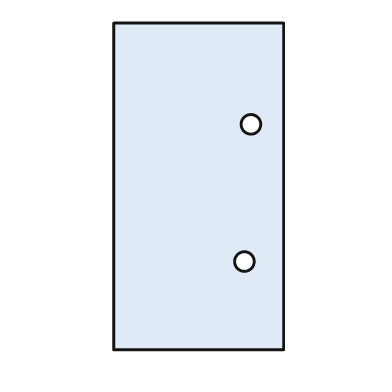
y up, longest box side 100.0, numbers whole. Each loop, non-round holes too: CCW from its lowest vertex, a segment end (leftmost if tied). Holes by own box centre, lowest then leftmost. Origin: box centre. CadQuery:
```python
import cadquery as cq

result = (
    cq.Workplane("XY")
    .moveTo(-26.0, -50.0)
    .lineTo(26.0, -50.0)
    .lineTo(26.0, 50.0)
    .lineTo(-26.0, 50.0)
    .close()
    .moveTo(14.0, -23.0)
    .circle(3.0)
    .moveTo(16.0, 19.0)
    .circle(3.0)
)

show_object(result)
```